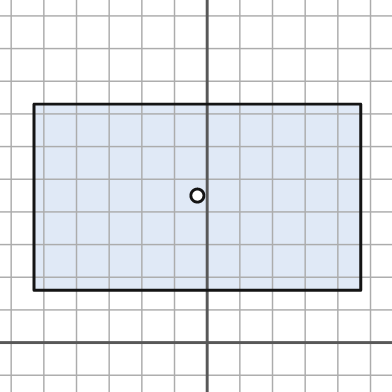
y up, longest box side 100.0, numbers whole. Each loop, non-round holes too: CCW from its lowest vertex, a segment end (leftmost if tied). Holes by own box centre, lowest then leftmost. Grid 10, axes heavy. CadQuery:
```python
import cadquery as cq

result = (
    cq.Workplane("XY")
    .moveTo(-53.0, 16.0)
    .lineTo(47.0, 16.0)
    .lineTo(47.0, 73.0)
    .lineTo(-53.0, 73.0)
    .close()
    .moveTo(-3.0, 45.0)
    .circle(2.0)
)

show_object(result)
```